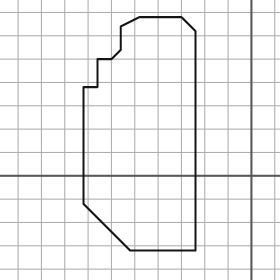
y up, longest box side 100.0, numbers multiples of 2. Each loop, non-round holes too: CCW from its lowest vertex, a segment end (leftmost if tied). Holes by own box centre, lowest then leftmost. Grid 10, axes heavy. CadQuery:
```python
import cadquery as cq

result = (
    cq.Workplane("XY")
    .moveTo(-52.0, -32.0)
    .lineTo(-24.0, -32.0)
    .lineTo(-24.0, 62.0)
    .lineTo(-30.0, 68.0)
    .lineTo(-48.0, 68.0)
    .lineTo(-56.0, 64.0)
    .lineTo(-56.0, 54.0)
    .lineTo(-60.0, 50.0)
    .lineTo(-66.0, 50.0)
    .lineTo(-66.0, 38.0)
    .lineTo(-72.0, 38.0)
    .lineTo(-72.0, -12.0)
    .close()
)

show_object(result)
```